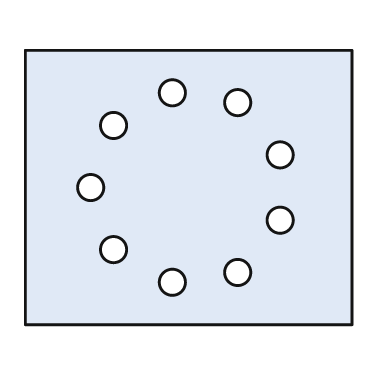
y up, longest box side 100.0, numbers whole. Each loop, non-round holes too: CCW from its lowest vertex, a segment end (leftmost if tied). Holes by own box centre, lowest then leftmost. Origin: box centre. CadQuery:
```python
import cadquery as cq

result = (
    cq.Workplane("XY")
    .moveTo(-50.0, -42.0)
    .lineTo(50.0, -42.0)
    .lineTo(50.0, 42.0)
    .lineTo(-50.0, 42.0)
    .close()
    .moveTo(-5.0, -29.0)
    .circle(4.0)
    .moveTo(15.0, -26.0)
    .circle(4.0)
    .moveTo(-23.0, -19.0)
    .circle(4.0)
    .moveTo(28.0, -10.0)
    .circle(4.0)
    .moveTo(-30.0, 0.0)
    .circle(4.0)
    .moveTo(28.0, 10.0)
    .circle(4.0)
    .moveTo(-23.0, 19.0)
    .circle(4.0)
    .moveTo(15.0, 26.0)
    .circle(4.0)
    .moveTo(-5.0, 29.0)
    .circle(4.0)
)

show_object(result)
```